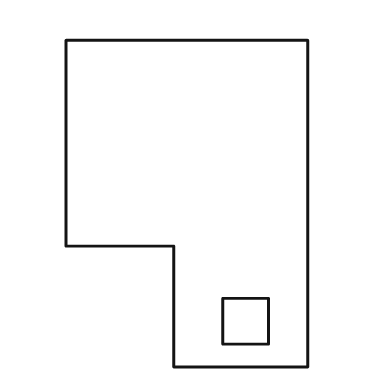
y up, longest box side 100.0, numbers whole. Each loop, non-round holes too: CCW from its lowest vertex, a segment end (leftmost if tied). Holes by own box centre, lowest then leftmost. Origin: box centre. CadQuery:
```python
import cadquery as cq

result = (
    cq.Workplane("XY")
    .moveTo(-4.0, -50.0)
    .lineTo(37.0, -50.0)
    .lineTo(37.0, 50.0)
    .lineTo(-37.0, 50.0)
    .lineTo(-37.0, -13.0)
    .lineTo(-4.0, -13.0)
    .close()
    .moveTo(11.0, -43.0)
    .lineTo(25.0, -43.0)
    .lineTo(25.0, -29.0)
    .lineTo(11.0, -29.0)
    .close()
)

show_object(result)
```